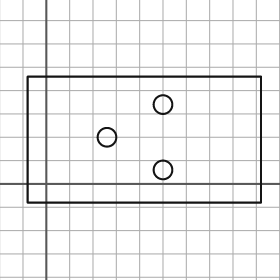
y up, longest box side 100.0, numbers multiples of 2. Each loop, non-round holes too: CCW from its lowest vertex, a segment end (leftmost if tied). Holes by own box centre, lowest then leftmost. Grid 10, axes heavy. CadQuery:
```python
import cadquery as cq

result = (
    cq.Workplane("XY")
    .moveTo(-8.0, -8.0)
    .lineTo(92.0, -8.0)
    .lineTo(92.0, 46.0)
    .lineTo(-8.0, 46.0)
    .close()
    .moveTo(50.0, 6.0)
    .circle(4.0)
    .moveTo(26.0, 20.0)
    .circle(4.0)
    .moveTo(50.0, 34.0)
    .circle(4.0)
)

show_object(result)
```